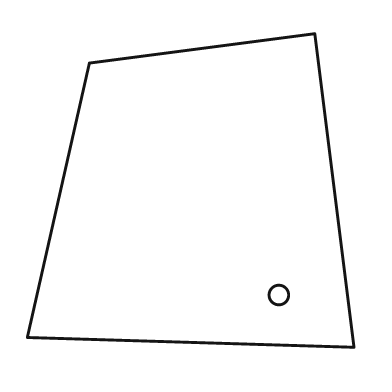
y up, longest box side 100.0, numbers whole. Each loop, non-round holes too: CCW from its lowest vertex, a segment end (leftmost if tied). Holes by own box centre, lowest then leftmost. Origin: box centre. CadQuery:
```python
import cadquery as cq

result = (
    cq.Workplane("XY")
    .moveTo(50.0, -48.0)
    .lineTo(38.0, 48.0)
    .lineTo(-31.0, 39.0)
    .lineTo(-50.0, -45.0)
    .close()
    .moveTo(27.0, -32.0)
    .circle(3.0)
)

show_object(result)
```